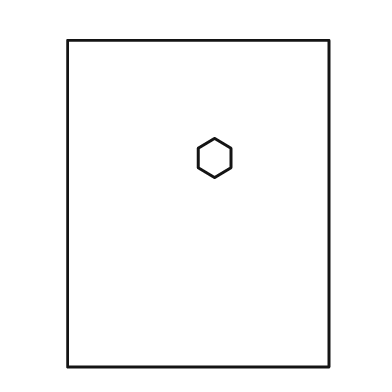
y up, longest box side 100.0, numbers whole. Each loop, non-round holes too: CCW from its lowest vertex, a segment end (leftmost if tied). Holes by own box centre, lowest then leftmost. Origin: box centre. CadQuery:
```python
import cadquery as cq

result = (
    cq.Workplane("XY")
    .moveTo(-40.0, -50.0)
    .lineTo(40.0, -50.0)
    .lineTo(40.0, 50.0)
    .lineTo(-40.0, 50.0)
    .close()
    .moveTo(5.0, 8.0)
    .lineTo(10.0, 11.0)
    .lineTo(10.0, 17.0)
    .lineTo(5.0, 20.0)
    .lineTo(0.0, 17.0)
    .lineTo(0.0, 11.0)
    .close()
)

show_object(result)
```